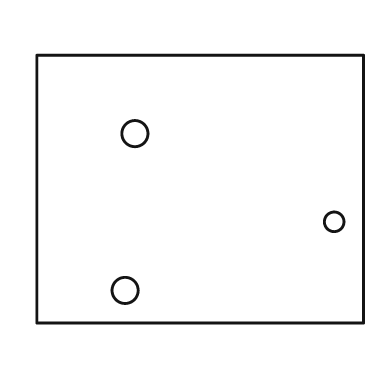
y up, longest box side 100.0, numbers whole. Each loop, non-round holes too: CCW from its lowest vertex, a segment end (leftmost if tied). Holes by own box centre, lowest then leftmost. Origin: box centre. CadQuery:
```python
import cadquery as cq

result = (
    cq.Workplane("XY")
    .moveTo(-50.0, -41.0)
    .lineTo(50.0, -41.0)
    .lineTo(50.0, 41.0)
    .lineTo(-50.0, 41.0)
    .close()
    .moveTo(-23.0, -31.0)
    .circle(4.0)
    .moveTo(41.0, -10.0)
    .circle(3.0)
    .moveTo(-20.0, 17.0)
    .circle(4.0)
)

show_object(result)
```